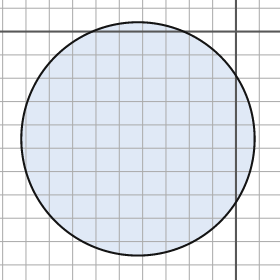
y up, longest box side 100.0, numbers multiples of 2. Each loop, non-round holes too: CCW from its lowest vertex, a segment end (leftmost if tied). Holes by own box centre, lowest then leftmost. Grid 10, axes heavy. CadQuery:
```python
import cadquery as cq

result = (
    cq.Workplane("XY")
    .moveTo(-42.0, -46.0)
    .circle(50.0)
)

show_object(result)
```